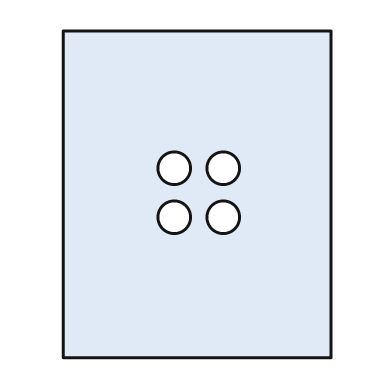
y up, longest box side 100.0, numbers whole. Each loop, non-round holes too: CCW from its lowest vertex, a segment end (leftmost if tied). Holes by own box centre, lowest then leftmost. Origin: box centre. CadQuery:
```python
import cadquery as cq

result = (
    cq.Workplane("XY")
    .moveTo(-41.0, -50.0)
    .lineTo(41.0, -50.0)
    .lineTo(41.0, 50.0)
    .lineTo(-41.0, 50.0)
    .close()
    .moveTo(-7.0, -7.0)
    .circle(5.0)
    .moveTo(8.0, -7.0)
    .circle(5.0)
    .moveTo(-7.0, 8.0)
    .circle(5.0)
    .moveTo(8.0, 8.0)
    .circle(5.0)
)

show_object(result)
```